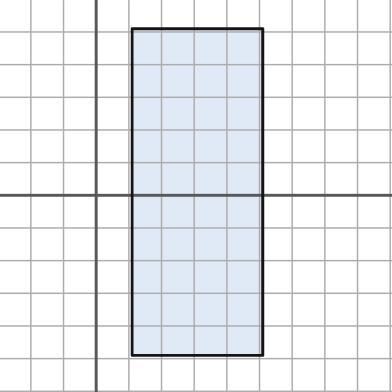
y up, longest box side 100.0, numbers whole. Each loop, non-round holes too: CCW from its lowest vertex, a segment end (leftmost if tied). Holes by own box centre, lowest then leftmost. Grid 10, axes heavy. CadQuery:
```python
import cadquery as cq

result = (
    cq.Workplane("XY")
    .moveTo(11.0, -49.0)
    .lineTo(51.0, -49.0)
    .lineTo(51.0, 51.0)
    .lineTo(11.0, 51.0)
    .close()
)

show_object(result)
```